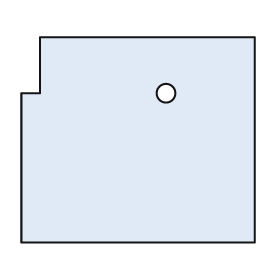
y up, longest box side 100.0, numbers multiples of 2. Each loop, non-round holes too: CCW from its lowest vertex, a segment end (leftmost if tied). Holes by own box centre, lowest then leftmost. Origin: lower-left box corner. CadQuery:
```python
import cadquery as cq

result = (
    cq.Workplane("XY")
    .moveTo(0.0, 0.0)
    .lineTo(100.0, 0.0)
    .lineTo(100.0, 88.0)
    .lineTo(8.0, 88.0)
    .lineTo(8.0, 64.0)
    .lineTo(0.0, 64.0)
    .close()
    .moveTo(62.0, 64.0)
    .circle(4.0)
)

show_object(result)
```